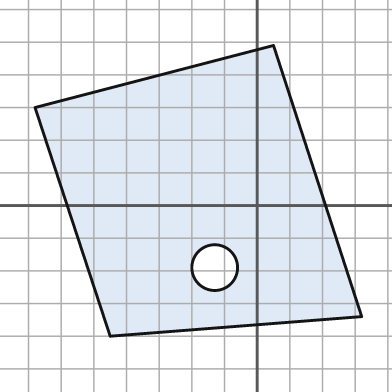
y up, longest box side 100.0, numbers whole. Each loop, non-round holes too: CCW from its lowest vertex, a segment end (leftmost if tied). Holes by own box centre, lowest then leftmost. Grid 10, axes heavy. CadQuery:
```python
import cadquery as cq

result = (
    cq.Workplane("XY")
    .moveTo(-45.0, -40.0)
    .lineTo(32.0, -34.0)
    .lineTo(5.0, 49.0)
    .lineTo(-68.0, 30.0)
    .close()
    .moveTo(-13.0, -19.0)
    .circle(7.0)
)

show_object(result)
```